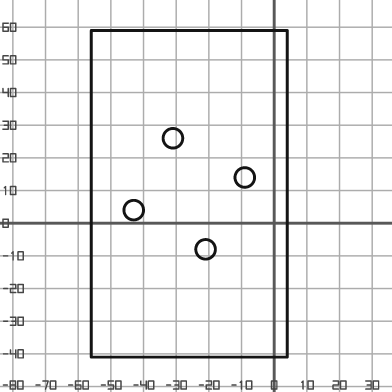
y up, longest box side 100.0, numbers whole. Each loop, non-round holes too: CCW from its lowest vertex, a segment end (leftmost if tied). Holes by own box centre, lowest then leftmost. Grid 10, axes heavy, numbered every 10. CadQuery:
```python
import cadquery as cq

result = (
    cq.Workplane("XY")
    .moveTo(-56.0, -41.0)
    .lineTo(4.0, -41.0)
    .lineTo(4.0, 59.0)
    .lineTo(-56.0, 59.0)
    .close()
    .moveTo(-21.0, -8.0)
    .circle(3.0)
    .moveTo(-43.0, 4.0)
    .circle(3.0)
    .moveTo(-9.0, 14.0)
    .circle(3.0)
    .moveTo(-31.0, 26.0)
    .circle(3.0)
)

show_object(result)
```